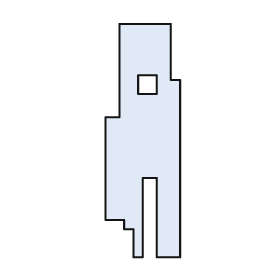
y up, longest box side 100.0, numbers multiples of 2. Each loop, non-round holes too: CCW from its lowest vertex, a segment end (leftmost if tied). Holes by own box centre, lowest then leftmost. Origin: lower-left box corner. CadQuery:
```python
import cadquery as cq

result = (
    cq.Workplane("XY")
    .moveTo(12.0, 0.0)
    .lineTo(16.0, 0.0)
    .lineTo(16.0, 34.0)
    .lineTo(22.0, 34.0)
    .lineTo(22.0, 0.0)
    .lineTo(32.0, 0.0)
    .lineTo(32.0, 76.0)
    .lineTo(28.0, 76.0)
    .lineTo(28.0, 100.0)
    .lineTo(6.0, 100.0)
    .lineTo(6.0, 60.0)
    .lineTo(0.0, 60.0)
    .lineTo(0.0, 16.0)
    .lineTo(8.0, 16.0)
    .lineTo(8.0, 12.0)
    .lineTo(12.0, 12.0)
    .close()
    .moveTo(14.0, 70.0)
    .lineTo(22.0, 70.0)
    .lineTo(22.0, 78.0)
    .lineTo(14.0, 78.0)
    .close()
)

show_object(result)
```